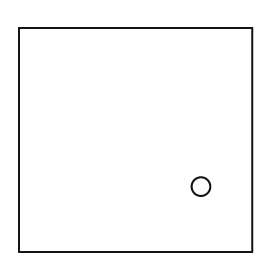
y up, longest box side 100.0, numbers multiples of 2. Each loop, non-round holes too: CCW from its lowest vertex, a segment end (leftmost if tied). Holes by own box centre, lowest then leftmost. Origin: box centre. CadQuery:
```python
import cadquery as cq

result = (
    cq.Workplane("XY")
    .moveTo(-50.0, -48.0)
    .lineTo(50.0, -48.0)
    .lineTo(50.0, 48.0)
    .lineTo(-50.0, 48.0)
    .close()
    .moveTo(28.0, -20.0)
    .circle(4.0)
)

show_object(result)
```